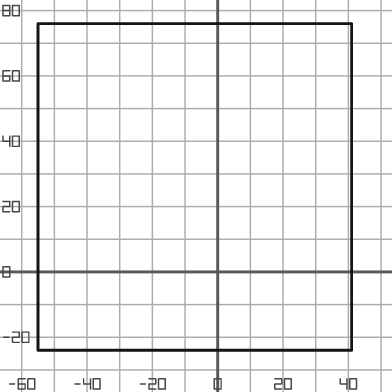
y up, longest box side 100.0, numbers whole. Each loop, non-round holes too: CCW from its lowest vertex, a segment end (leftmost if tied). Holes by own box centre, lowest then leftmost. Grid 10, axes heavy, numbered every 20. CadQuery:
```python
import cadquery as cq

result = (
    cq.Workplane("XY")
    .moveTo(-55.0, -24.0)
    .lineTo(41.0, -24.0)
    .lineTo(41.0, 76.0)
    .lineTo(-55.0, 76.0)
    .close()
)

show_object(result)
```